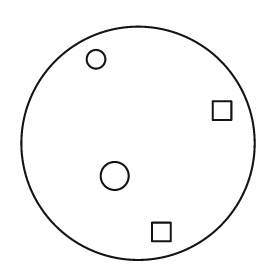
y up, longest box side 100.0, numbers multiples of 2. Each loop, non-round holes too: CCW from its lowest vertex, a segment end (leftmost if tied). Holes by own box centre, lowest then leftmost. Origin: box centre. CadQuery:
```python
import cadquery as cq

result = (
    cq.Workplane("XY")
    .moveTo(0.0, 0.0)
    .circle(50.0)
    .moveTo(6.0, -42.0)
    .lineTo(14.0, -42.0)
    .lineTo(14.0, -34.0)
    .lineTo(6.0, -34.0)
    .close()
    .moveTo(-10.0, -14.0)
    .circle(6.0)
    .moveTo(32.0, 10.0)
    .lineTo(40.0, 10.0)
    .lineTo(40.0, 18.0)
    .lineTo(32.0, 18.0)
    .close()
    .moveTo(-18.0, 36.0)
    .circle(4.0)
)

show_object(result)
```